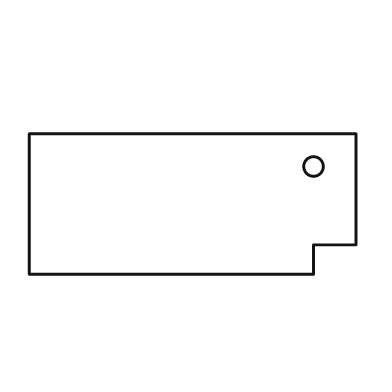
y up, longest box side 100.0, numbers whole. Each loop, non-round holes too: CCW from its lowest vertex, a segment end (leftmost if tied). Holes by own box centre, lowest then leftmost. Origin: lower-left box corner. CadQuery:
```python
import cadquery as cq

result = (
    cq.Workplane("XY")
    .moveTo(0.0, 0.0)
    .lineTo(87.0, 0.0)
    .lineTo(87.0, 9.0)
    .lineTo(100.0, 9.0)
    .lineTo(100.0, 43.0)
    .lineTo(0.0, 43.0)
    .close()
    .moveTo(87.0, 33.0)
    .circle(3.0)
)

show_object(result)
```